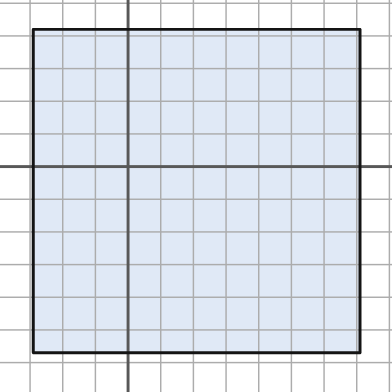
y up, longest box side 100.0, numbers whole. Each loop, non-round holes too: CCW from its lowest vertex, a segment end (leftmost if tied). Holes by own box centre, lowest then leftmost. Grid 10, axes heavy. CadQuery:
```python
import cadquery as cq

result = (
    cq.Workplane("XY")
    .moveTo(-29.0, -57.0)
    .lineTo(71.0, -57.0)
    .lineTo(71.0, 42.0)
    .lineTo(-29.0, 42.0)
    .close()
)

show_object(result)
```